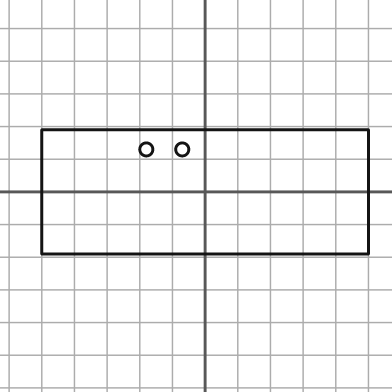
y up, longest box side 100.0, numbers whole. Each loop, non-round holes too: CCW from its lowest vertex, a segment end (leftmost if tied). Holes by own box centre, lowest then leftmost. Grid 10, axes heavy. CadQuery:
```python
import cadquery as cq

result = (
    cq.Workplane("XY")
    .moveTo(-50.0, -19.0)
    .lineTo(50.0, -19.0)
    .lineTo(50.0, 19.0)
    .lineTo(-50.0, 19.0)
    .close()
    .moveTo(-18.0, 13.0)
    .circle(2.0)
    .moveTo(-7.0, 13.0)
    .circle(2.0)
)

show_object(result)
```